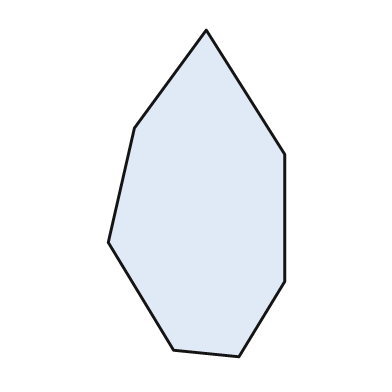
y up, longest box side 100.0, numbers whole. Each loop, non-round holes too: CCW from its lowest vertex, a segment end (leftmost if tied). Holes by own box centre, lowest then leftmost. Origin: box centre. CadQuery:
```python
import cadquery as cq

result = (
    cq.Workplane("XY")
    .moveTo(13.0, -50.0)
    .lineTo(27.0, -27.0)
    .lineTo(27.0, 12.0)
    .lineTo(3.0, 50.0)
    .lineTo(-19.0, 20.0)
    .lineTo(-27.0, -15.0)
    .lineTo(-7.0, -48.0)
    .close()
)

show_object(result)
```